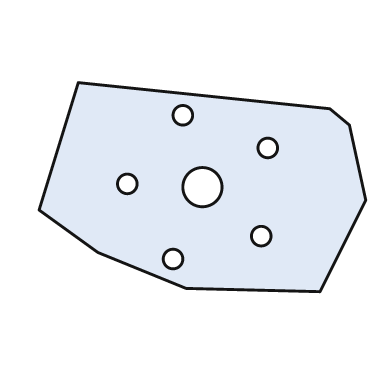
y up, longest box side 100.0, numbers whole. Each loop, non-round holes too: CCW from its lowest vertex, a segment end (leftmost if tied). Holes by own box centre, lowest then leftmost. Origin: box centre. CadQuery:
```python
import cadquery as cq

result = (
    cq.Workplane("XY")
    .moveTo(36.0, -32.0)
    .lineTo(50.0, -4.0)
    .lineTo(45.0, 19.0)
    .lineTo(39.0, 24.0)
    .lineTo(-38.0, 32.0)
    .lineTo(-50.0, -7.0)
    .lineTo(-32.0, -20.0)
    .lineTo(-5.0, -31.0)
    .close()
    .moveTo(-9.0, -22.0)
    .circle(3.0)
    .moveTo(18.0, -15.0)
    .circle(3.0)
    .moveTo(0.0, 0.0)
    .circle(6.0)
    .moveTo(-23.0, 1.0)
    .circle(3.0)
    .moveTo(20.0, 12.0)
    .circle(3.0)
    .moveTo(-6.0, 22.0)
    .circle(3.0)
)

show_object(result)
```